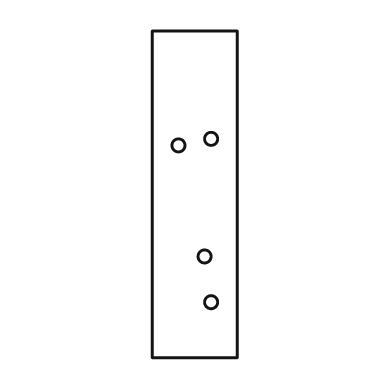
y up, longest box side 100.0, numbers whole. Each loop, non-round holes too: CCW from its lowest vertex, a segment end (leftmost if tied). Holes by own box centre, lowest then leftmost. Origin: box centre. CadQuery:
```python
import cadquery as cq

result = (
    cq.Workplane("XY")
    .moveTo(-13.0, -50.0)
    .lineTo(13.0, -50.0)
    .lineTo(13.0, 50.0)
    .lineTo(-13.0, 50.0)
    .close()
    .moveTo(5.0, -33.0)
    .circle(2.0)
    .moveTo(3.0, -19.0)
    .circle(2.0)
    .moveTo(-5.0, 15.0)
    .circle(2.0)
    .moveTo(5.0, 17.0)
    .circle(2.0)
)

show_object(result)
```